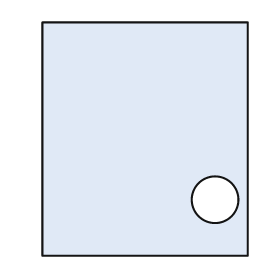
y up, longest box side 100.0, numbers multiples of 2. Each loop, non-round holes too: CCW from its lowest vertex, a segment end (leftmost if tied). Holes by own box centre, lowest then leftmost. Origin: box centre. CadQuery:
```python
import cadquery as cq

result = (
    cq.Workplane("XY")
    .moveTo(-44.0, -50.0)
    .lineTo(44.0, -50.0)
    .lineTo(44.0, 50.0)
    .lineTo(-44.0, 50.0)
    .close()
    .moveTo(30.0, -26.0)
    .circle(10.0)
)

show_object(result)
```